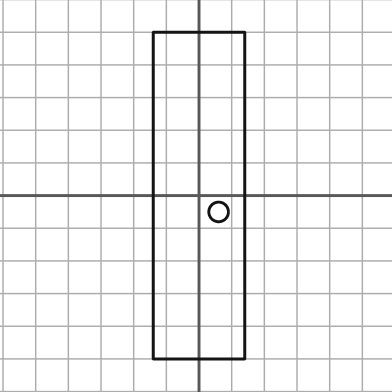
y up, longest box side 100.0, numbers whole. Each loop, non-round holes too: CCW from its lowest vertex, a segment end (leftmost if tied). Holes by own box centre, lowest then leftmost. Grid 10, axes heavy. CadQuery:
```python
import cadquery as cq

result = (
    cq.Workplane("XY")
    .moveTo(-14.0, -50.0)
    .lineTo(14.0, -50.0)
    .lineTo(14.0, 50.0)
    .lineTo(-14.0, 50.0)
    .close()
    .moveTo(6.0, -5.0)
    .circle(3.0)
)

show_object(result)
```